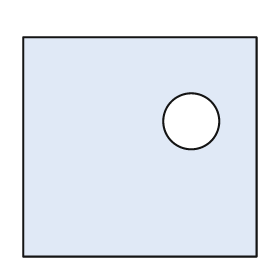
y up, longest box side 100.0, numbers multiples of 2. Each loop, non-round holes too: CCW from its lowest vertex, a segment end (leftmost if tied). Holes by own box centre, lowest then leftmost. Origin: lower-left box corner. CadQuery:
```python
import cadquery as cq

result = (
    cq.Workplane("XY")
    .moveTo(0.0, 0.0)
    .lineTo(100.0, 0.0)
    .lineTo(100.0, 94.0)
    .lineTo(0.0, 94.0)
    .close()
    .moveTo(72.0, 58.0)
    .circle(12.0)
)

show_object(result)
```